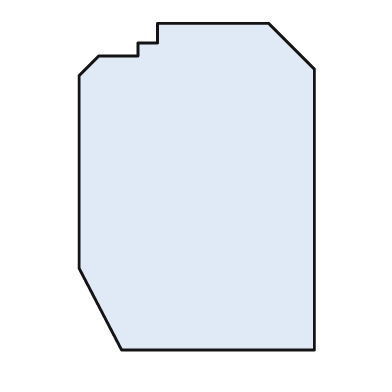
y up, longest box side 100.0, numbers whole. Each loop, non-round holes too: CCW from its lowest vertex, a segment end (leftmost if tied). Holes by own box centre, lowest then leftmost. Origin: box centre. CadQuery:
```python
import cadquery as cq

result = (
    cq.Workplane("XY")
    .moveTo(-23.0, -50.0)
    .lineTo(36.0, -50.0)
    .lineTo(36.0, 36.0)
    .lineTo(22.0, 50.0)
    .lineTo(-12.0, 50.0)
    .lineTo(-12.0, 44.0)
    .lineTo(-18.0, 44.0)
    .lineTo(-18.0, 40.0)
    .lineTo(-30.0, 40.0)
    .lineTo(-36.0, 34.0)
    .lineTo(-36.0, -25.0)
    .close()
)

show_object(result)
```